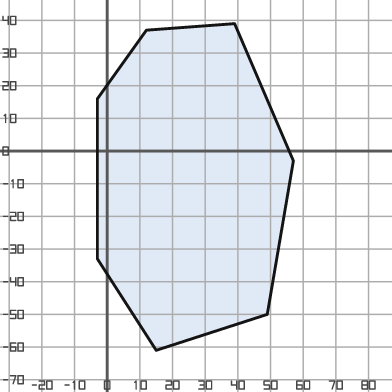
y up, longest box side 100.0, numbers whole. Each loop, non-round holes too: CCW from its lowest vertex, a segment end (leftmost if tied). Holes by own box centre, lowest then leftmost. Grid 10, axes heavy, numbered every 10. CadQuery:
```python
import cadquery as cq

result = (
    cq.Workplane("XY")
    .moveTo(15.0, -61.0)
    .lineTo(49.0, -50.0)
    .lineTo(57.0, -3.0)
    .lineTo(39.0, 39.0)
    .lineTo(12.0, 37.0)
    .lineTo(-3.0, 16.0)
    .lineTo(-3.0, -33.0)
    .close()
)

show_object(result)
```